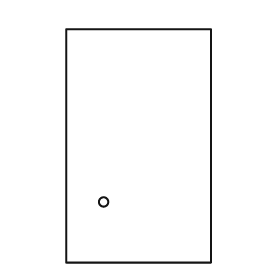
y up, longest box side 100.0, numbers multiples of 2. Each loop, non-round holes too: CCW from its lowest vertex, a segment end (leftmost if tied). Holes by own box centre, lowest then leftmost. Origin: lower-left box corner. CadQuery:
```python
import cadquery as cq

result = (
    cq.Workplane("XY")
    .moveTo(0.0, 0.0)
    .lineTo(62.0, 0.0)
    .lineTo(62.0, 100.0)
    .lineTo(0.0, 100.0)
    .close()
    .moveTo(16.0, 26.0)
    .circle(2.0)
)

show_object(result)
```